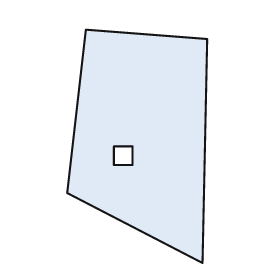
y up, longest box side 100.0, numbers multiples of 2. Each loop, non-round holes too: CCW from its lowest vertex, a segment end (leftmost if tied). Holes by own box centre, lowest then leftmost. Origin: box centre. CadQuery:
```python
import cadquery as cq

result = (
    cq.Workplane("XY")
    .moveTo(28.0, -50.0)
    .lineTo(30.0, 46.0)
    .lineTo(-22.0, 50.0)
    .lineTo(-30.0, -20.0)
    .close()
    .moveTo(-10.0, -8.0)
    .lineTo(-2.0, -8.0)
    .lineTo(-2.0, 0.0)
    .lineTo(-10.0, 0.0)
    .close()
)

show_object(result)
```